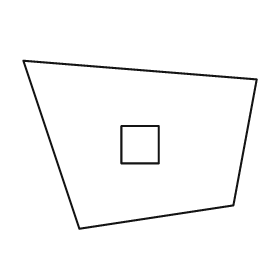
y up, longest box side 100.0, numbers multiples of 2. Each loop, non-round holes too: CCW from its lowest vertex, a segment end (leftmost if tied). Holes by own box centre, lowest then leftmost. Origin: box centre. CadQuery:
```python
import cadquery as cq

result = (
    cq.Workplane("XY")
    .moveTo(-26.0, -36.0)
    .lineTo(40.0, -26.0)
    .lineTo(50.0, 28.0)
    .lineTo(-50.0, 36.0)
    .close()
    .moveTo(-8.0, -8.0)
    .lineTo(8.0, -8.0)
    .lineTo(8.0, 8.0)
    .lineTo(-8.0, 8.0)
    .close()
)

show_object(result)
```